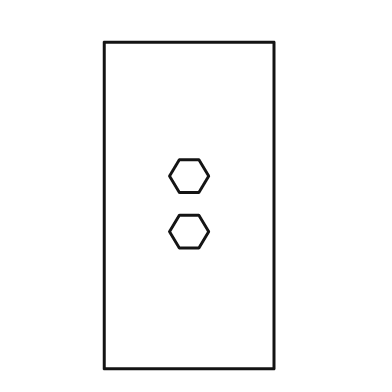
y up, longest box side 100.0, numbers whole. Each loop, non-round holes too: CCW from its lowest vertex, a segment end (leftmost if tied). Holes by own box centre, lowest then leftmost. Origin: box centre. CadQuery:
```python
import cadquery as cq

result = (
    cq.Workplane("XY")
    .moveTo(-26.0, -50.0)
    .lineTo(26.0, -50.0)
    .lineTo(26.0, 50.0)
    .lineTo(-26.0, 50.0)
    .close()
    .moveTo(-3.0, -13.0)
    .lineTo(3.0, -13.0)
    .lineTo(6.0, -8.0)
    .lineTo(3.0, -3.0)
    .lineTo(-3.0, -3.0)
    .lineTo(-6.0, -8.0)
    .close()
    .moveTo(-3.0, 4.0)
    .lineTo(3.0, 4.0)
    .lineTo(6.0, 9.0)
    .lineTo(3.0, 14.0)
    .lineTo(-3.0, 14.0)
    .lineTo(-6.0, 9.0)
    .close()
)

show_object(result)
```